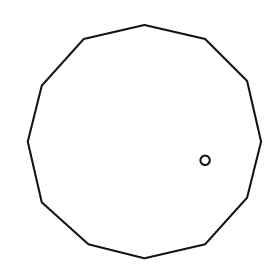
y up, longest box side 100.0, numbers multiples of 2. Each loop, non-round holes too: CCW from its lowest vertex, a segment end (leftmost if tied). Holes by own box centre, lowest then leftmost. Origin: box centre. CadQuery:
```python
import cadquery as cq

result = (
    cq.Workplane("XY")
    .moveTo(0.0, -50.0)
    .lineTo(26.0, -44.0)
    .lineTo(44.0, -24.0)
    .lineTo(50.0, 0.0)
    .lineTo(44.0, 26.0)
    .lineTo(26.0, 44.0)
    .lineTo(0.0, 50.0)
    .lineTo(-26.0, 44.0)
    .lineTo(-44.0, 24.0)
    .lineTo(-50.0, 0.0)
    .lineTo(-44.0, -26.0)
    .lineTo(-24.0, -44.0)
    .close()
    .moveTo(26.0, -8.0)
    .circle(2.0)
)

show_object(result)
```